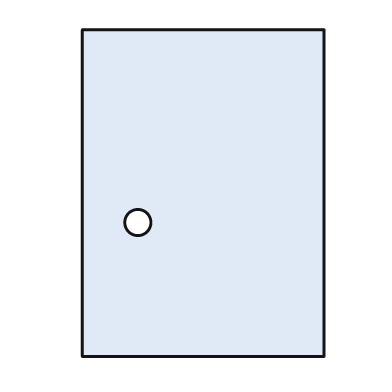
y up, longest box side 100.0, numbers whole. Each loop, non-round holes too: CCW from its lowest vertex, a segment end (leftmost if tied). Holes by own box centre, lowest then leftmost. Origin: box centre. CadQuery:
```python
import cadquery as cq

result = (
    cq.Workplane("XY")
    .moveTo(-37.0, -50.0)
    .lineTo(37.0, -50.0)
    .lineTo(37.0, 50.0)
    .lineTo(-37.0, 50.0)
    .close()
    .moveTo(-20.0, -9.0)
    .circle(4.0)
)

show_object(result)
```